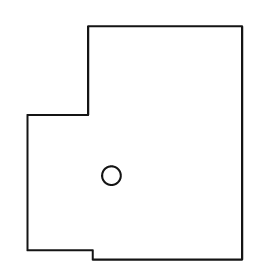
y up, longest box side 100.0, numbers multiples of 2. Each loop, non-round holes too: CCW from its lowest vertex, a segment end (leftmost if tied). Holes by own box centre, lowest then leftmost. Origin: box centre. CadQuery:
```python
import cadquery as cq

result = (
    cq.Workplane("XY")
    .moveTo(-18.0, -50.0)
    .lineTo(46.0, -50.0)
    .lineTo(46.0, 50.0)
    .lineTo(-20.0, 50.0)
    .lineTo(-20.0, 12.0)
    .lineTo(-46.0, 12.0)
    .lineTo(-46.0, -46.0)
    .lineTo(-18.0, -46.0)
    .close()
    .moveTo(-10.0, -14.0)
    .circle(4.0)
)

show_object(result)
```